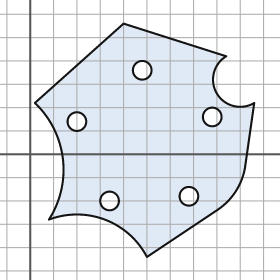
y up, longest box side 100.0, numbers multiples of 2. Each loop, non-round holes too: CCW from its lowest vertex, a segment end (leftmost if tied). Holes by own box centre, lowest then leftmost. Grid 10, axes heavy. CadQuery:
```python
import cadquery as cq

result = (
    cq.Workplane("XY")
    .moveTo(50.0, -44.0)
    .lineTo(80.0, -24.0)
    .threePointArc((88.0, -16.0), (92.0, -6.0))
    .lineTo(96.0, 22.0)
    .threePointArc((80.0, 26.0), (84.0, 42.0))
    .lineTo(40.0, 56.0)
    .lineTo(2.0, 22.0)
    .threePointArc((14.0, -2.0), (8.0, -28.0))
    .threePointArc((32.0, -28.0), (50.0, -44.0))
    .close()
    .moveTo(34.0, -20.0)
    .circle(4.0)
    .moveTo(68.0, -18.0)
    .circle(4.0)
    .moveTo(20.0, 14.0)
    .circle(4.0)
    .moveTo(78.0, 16.0)
    .circle(4.0)
    .moveTo(48.0, 36.0)
    .circle(4.0)
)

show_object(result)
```